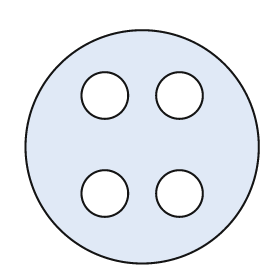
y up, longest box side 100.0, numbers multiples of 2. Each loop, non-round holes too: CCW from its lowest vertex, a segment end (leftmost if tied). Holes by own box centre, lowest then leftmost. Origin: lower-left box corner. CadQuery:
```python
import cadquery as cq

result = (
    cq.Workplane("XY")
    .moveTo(50.0, 50.0)
    .circle(50.0)
    .moveTo(34.0, 30.0)
    .circle(10.0)
    .moveTo(66.0, 30.0)
    .circle(10.0)
    .moveTo(34.0, 72.0)
    .circle(10.0)
    .moveTo(66.0, 72.0)
    .circle(10.0)
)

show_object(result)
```